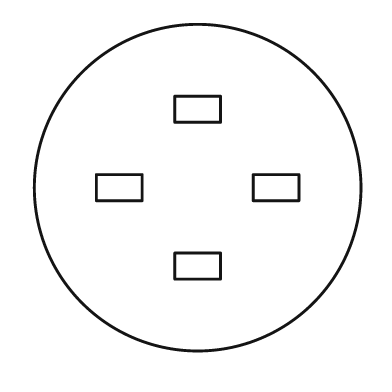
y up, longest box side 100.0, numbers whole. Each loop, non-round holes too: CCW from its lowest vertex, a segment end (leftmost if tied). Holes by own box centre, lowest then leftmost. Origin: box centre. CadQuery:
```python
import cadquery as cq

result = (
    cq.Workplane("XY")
    .moveTo(0.0, 0.0)
    .circle(50.0)
    .moveTo(-7.0, -28.0)
    .lineTo(7.0, -28.0)
    .lineTo(7.0, -20.0)
    .lineTo(-7.0, -20.0)
    .close()
    .moveTo(-31.0, -4.0)
    .lineTo(-17.0, -4.0)
    .lineTo(-17.0, 4.0)
    .lineTo(-31.0, 4.0)
    .close()
    .moveTo(17.0, -4.0)
    .lineTo(31.0, -4.0)
    .lineTo(31.0, 4.0)
    .lineTo(17.0, 4.0)
    .close()
    .moveTo(-7.0, 20.0)
    .lineTo(7.0, 20.0)
    .lineTo(7.0, 28.0)
    .lineTo(-7.0, 28.0)
    .close()
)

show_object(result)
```